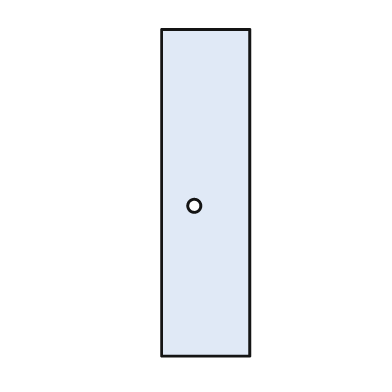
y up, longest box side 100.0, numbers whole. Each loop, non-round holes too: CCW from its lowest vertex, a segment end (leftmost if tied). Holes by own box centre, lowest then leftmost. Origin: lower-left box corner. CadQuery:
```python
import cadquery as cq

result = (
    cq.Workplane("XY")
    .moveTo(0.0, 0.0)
    .lineTo(27.0, 0.0)
    .lineTo(27.0, 100.0)
    .lineTo(0.0, 100.0)
    .close()
    .moveTo(10.0, 46.0)
    .circle(2.0)
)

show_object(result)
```